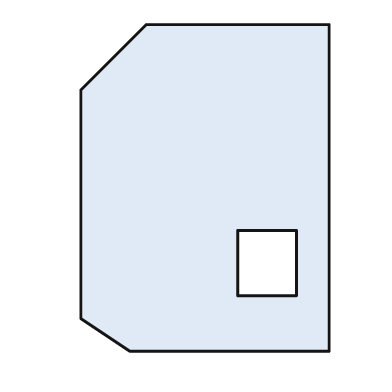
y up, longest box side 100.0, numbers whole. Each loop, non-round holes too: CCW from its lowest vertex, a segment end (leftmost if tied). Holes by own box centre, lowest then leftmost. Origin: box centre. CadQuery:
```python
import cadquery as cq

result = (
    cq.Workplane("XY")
    .moveTo(-23.0, -50.0)
    .lineTo(38.0, -50.0)
    .lineTo(38.0, 50.0)
    .lineTo(-18.0, 50.0)
    .lineTo(-38.0, 30.0)
    .lineTo(-38.0, -40.0)
    .close()
    .moveTo(10.0, -33.0)
    .lineTo(28.0, -33.0)
    .lineTo(28.0, -13.0)
    .lineTo(10.0, -13.0)
    .close()
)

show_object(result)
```